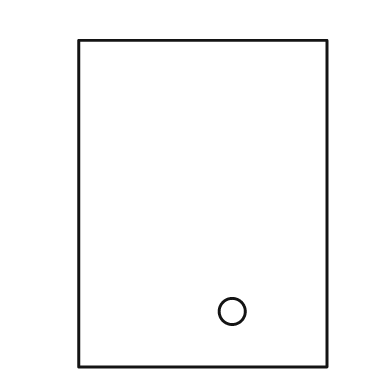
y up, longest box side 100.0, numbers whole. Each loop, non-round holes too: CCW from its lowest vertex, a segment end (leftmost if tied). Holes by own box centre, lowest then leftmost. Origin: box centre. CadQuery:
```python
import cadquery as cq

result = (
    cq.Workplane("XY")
    .moveTo(-38.0, -50.0)
    .lineTo(38.0, -50.0)
    .lineTo(38.0, 50.0)
    .lineTo(-38.0, 50.0)
    .close()
    .moveTo(9.0, -33.0)
    .circle(4.0)
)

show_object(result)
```